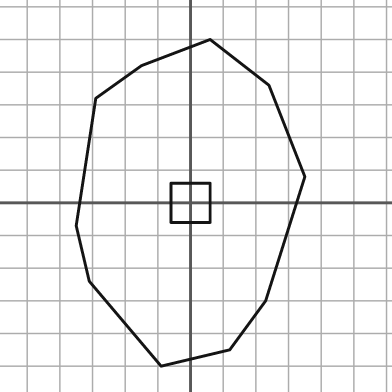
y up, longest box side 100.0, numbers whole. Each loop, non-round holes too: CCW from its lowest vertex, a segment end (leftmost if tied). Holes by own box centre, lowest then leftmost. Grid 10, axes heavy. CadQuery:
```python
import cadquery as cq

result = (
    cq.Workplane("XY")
    .moveTo(-9.0, -50.0)
    .lineTo(12.0, -45.0)
    .lineTo(23.0, -30.0)
    .lineTo(35.0, 8.0)
    .lineTo(24.0, 36.0)
    .lineTo(6.0, 50.0)
    .lineTo(-15.0, 42.0)
    .lineTo(-29.0, 32.0)
    .lineTo(-35.0, -7.0)
    .lineTo(-31.0, -24.0)
    .close()
    .moveTo(-6.0, -6.0)
    .lineTo(6.0, -6.0)
    .lineTo(6.0, 6.0)
    .lineTo(-6.0, 6.0)
    .close()
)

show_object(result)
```